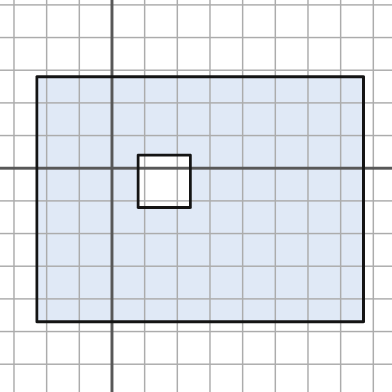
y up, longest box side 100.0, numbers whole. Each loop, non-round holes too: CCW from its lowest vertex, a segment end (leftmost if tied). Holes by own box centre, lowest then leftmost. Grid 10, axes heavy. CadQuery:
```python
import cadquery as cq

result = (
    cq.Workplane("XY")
    .moveTo(-23.0, -47.0)
    .lineTo(77.0, -47.0)
    .lineTo(77.0, 28.0)
    .lineTo(-23.0, 28.0)
    .close()
    .moveTo(8.0, -12.0)
    .lineTo(24.0, -12.0)
    .lineTo(24.0, 4.0)
    .lineTo(8.0, 4.0)
    .close()
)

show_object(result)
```